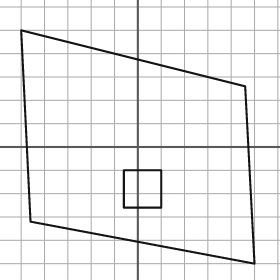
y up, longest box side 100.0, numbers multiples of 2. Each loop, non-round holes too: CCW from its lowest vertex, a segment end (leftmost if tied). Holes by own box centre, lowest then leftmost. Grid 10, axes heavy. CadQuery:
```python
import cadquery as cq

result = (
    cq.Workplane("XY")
    .moveTo(50.0, -50.0)
    .lineTo(46.0, 26.0)
    .lineTo(-50.0, 50.0)
    .lineTo(-46.0, -32.0)
    .close()
    .moveTo(-6.0, -26.0)
    .lineTo(10.0, -26.0)
    .lineTo(10.0, -10.0)
    .lineTo(-6.0, -10.0)
    .close()
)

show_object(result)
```